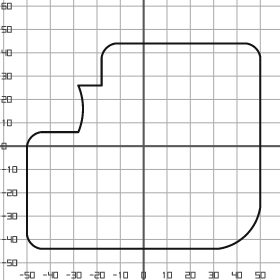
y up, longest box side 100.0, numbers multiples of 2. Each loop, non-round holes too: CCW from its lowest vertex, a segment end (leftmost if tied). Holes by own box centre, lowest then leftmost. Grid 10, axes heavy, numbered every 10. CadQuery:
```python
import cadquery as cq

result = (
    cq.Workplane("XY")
    .moveTo(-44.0, -44.0)
    .lineTo(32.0, -44.0)
    .threePointArc((44.0, -38.0), (50.0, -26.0))
    .lineTo(50.0, 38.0)
    .threePointArc((48.0, 42.0), (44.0, 44.0))
    .lineTo(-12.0, 44.0)
    .threePointArc((-16.0, 42.0), (-18.0, 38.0))
    .lineTo(-18.0, 26.0)
    .lineTo(-28.0, 26.0)
    .threePointArc((-26.0, 16.0), (-28.0, 6.0))
    .lineTo(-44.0, 6.0)
    .threePointArc((-48.0, 4.0), (-50.0, 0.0))
    .lineTo(-50.0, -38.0)
    .threePointArc((-48.0, -42.0), (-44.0, -44.0))
    .close()
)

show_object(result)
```